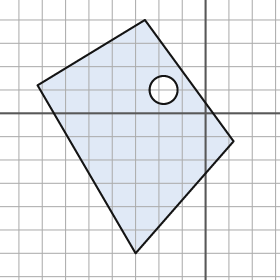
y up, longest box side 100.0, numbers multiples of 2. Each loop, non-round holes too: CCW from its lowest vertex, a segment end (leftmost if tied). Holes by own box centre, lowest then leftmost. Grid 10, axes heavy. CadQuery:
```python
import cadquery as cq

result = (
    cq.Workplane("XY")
    .moveTo(-30.0, -60.0)
    .lineTo(12.0, -12.0)
    .lineTo(-26.0, 40.0)
    .lineTo(-72.0, 12.0)
    .close()
    .moveTo(-18.0, 10.0)
    .circle(6.0)
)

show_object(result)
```